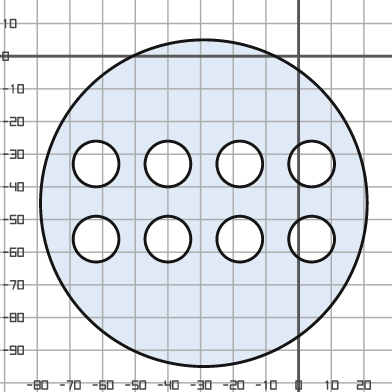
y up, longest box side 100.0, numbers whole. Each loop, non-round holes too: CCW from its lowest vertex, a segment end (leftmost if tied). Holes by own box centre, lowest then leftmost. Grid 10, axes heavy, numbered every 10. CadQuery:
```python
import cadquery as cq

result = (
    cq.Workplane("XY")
    .moveTo(-29.0, -45.0)
    .circle(50.0)
    .moveTo(-62.0, -56.0)
    .circle(7.0)
    .moveTo(-40.0, -56.0)
    .circle(7.0)
    .moveTo(-18.0, -56.0)
    .circle(7.0)
    .moveTo(4.0, -56.0)
    .circle(7.0)
    .moveTo(-62.0, -33.0)
    .circle(7.0)
    .moveTo(-40.0, -33.0)
    .circle(7.0)
    .moveTo(-18.0, -33.0)
    .circle(7.0)
    .moveTo(4.0, -33.0)
    .circle(7.0)
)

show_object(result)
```